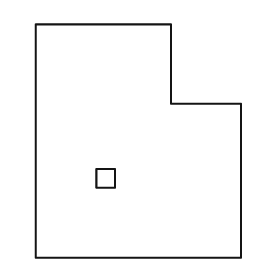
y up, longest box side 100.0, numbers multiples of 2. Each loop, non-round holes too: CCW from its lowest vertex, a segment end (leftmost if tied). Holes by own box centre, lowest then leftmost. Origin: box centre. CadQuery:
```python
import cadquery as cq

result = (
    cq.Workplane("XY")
    .moveTo(-44.0, -50.0)
    .lineTo(44.0, -50.0)
    .lineTo(44.0, 16.0)
    .lineTo(14.0, 16.0)
    .lineTo(14.0, 50.0)
    .lineTo(-44.0, 50.0)
    .close()
    .moveTo(-18.0, -20.0)
    .lineTo(-10.0, -20.0)
    .lineTo(-10.0, -12.0)
    .lineTo(-18.0, -12.0)
    .close()
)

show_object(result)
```